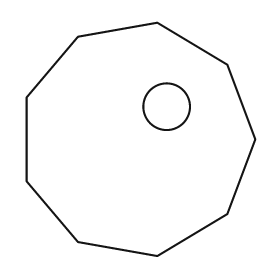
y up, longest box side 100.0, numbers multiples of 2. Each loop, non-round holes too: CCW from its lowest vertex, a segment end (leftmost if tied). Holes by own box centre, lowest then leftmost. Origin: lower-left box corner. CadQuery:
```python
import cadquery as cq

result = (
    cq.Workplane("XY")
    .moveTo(56.0, 0.0)
    .lineTo(86.0, 18.0)
    .lineTo(98.0, 50.0)
    .lineTo(86.0, 82.0)
    .lineTo(56.0, 100.0)
    .lineTo(22.0, 94.0)
    .lineTo(0.0, 68.0)
    .lineTo(0.0, 32.0)
    .lineTo(22.0, 6.0)
    .close()
    .moveTo(60.0, 64.0)
    .circle(10.0)
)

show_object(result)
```